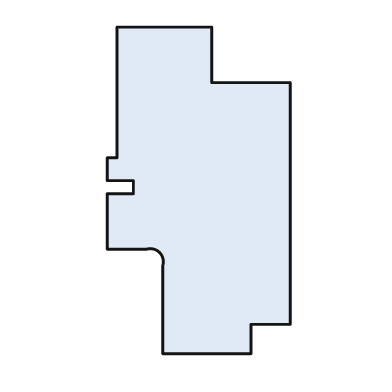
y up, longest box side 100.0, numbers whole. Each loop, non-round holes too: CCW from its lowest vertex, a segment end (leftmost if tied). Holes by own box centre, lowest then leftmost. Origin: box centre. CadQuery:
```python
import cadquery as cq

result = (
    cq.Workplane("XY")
    .moveTo(-11.0, -50.0)
    .lineTo(16.0, -50.0)
    .lineTo(16.0, -41.0)
    .lineTo(28.0, -41.0)
    .lineTo(28.0, 33.0)
    .lineTo(4.0, 33.0)
    .lineTo(4.0, 50.0)
    .lineTo(-25.0, 50.0)
    .lineTo(-25.0, 10.0)
    .lineTo(-28.0, 10.0)
    .lineTo(-28.0, 3.0)
    .lineTo(-20.0, 3.0)
    .lineTo(-20.0, -1.0)
    .lineTo(-28.0, -1.0)
    .lineTo(-28.0, -18.0)
    .lineTo(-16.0, -18.0)
    .threePointArc((-12.0, -19.0), (-11.0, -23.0))
    .close()
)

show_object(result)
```